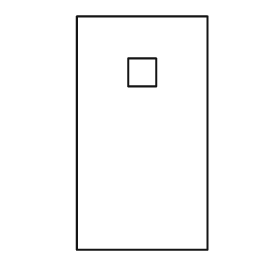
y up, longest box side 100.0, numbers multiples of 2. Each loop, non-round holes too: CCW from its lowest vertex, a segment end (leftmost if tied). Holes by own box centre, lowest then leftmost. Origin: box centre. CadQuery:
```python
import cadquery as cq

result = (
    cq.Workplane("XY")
    .moveTo(-28.0, -50.0)
    .lineTo(28.0, -50.0)
    .lineTo(28.0, 50.0)
    .lineTo(-28.0, 50.0)
    .close()
    .moveTo(-6.0, 20.0)
    .lineTo(6.0, 20.0)
    .lineTo(6.0, 32.0)
    .lineTo(-6.0, 32.0)
    .close()
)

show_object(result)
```